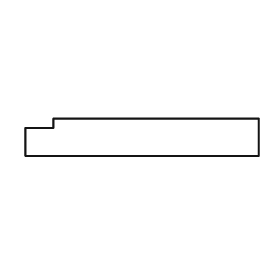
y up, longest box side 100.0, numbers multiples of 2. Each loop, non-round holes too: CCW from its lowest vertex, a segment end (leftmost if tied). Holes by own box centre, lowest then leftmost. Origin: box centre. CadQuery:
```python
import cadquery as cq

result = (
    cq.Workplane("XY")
    .moveTo(-50.0, -8.0)
    .lineTo(50.0, -8.0)
    .lineTo(50.0, 8.0)
    .lineTo(-38.0, 8.0)
    .lineTo(-38.0, 4.0)
    .lineTo(-50.0, 4.0)
    .close()
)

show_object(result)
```